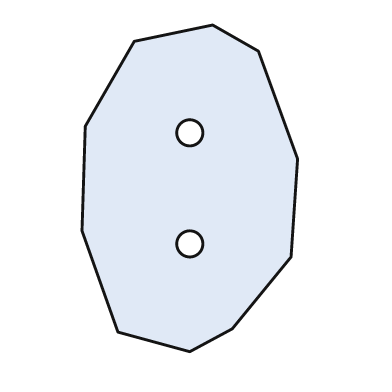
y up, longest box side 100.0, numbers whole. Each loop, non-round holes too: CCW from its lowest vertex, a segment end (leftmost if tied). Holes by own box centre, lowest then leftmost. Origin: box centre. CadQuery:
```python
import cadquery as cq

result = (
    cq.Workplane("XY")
    .moveTo(0.0, -50.0)
    .lineTo(13.0, -43.0)
    .lineTo(31.0, -21.0)
    .lineTo(33.0, 9.0)
    .lineTo(21.0, 42.0)
    .lineTo(7.0, 50.0)
    .lineTo(-17.0, 45.0)
    .lineTo(-32.0, 19.0)
    .lineTo(-33.0, -13.0)
    .lineTo(-22.0, -44.0)
    .close()
    .moveTo(0.0, -17.0)
    .circle(4.0)
    .moveTo(0.0, 17.0)
    .circle(4.0)
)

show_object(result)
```